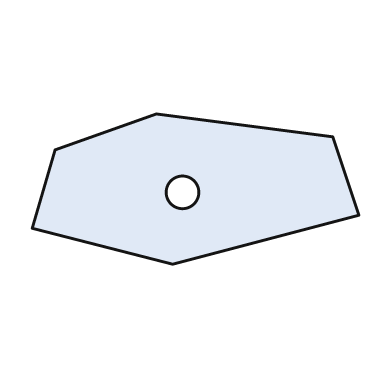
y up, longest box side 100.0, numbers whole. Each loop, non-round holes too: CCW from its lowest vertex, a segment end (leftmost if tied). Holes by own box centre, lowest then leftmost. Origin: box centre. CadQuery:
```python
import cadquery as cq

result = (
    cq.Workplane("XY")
    .moveTo(-7.0, -23.0)
    .lineTo(50.0, -8.0)
    .lineTo(42.0, 16.0)
    .lineTo(-12.0, 23.0)
    .lineTo(-43.0, 12.0)
    .lineTo(-50.0, -12.0)
    .close()
    .moveTo(-4.0, -1.0)
    .circle(5.0)
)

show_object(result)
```